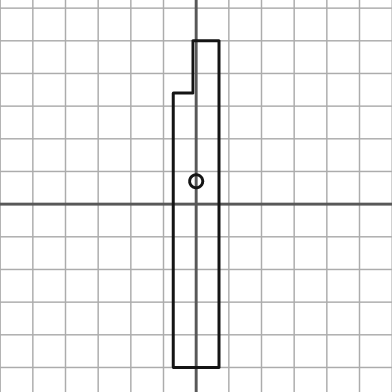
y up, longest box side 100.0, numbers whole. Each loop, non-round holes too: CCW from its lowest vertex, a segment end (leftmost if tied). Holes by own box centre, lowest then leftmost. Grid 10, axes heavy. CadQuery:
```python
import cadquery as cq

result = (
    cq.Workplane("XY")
    .moveTo(-7.0, -50.0)
    .lineTo(7.0, -50.0)
    .lineTo(7.0, 50.0)
    .lineTo(-1.0, 50.0)
    .lineTo(-1.0, 34.0)
    .lineTo(-7.0, 34.0)
    .close()
    .moveTo(0.0, 7.0)
    .circle(2.0)
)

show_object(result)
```